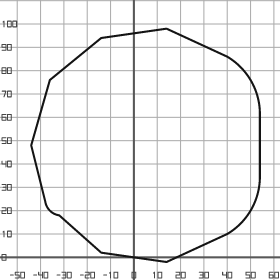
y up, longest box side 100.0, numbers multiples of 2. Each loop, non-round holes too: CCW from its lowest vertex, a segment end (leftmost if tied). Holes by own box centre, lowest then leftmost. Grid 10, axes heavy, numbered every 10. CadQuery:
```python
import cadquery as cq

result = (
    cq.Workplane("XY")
    .moveTo(14.0, -2.0)
    .lineTo(40.0, 10.0)
    .threePointArc((50.0, 20.0), (54.0, 34.0))
    .lineTo(54.0, 62.0)
    .threePointArc((50.0, 76.0), (40.0, 86.0))
    .lineTo(14.0, 98.0)
    .lineTo(-14.0, 94.0)
    .lineTo(-36.0, 76.0)
    .lineTo(-44.0, 48.0)
    .lineTo(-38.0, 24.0)
    .threePointArc((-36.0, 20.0), (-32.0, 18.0))
    .lineTo(-14.0, 2.0)
    .close()
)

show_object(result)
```